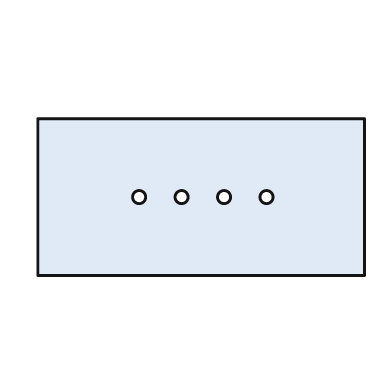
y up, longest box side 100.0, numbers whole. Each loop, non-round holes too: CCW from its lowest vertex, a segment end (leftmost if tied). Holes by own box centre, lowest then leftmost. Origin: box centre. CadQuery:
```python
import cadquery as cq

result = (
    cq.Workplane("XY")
    .moveTo(-50.0, -24.0)
    .lineTo(50.0, -24.0)
    .lineTo(50.0, 24.0)
    .lineTo(-50.0, 24.0)
    .close()
    .moveTo(-19.0, 0.0)
    .circle(2.0)
    .moveTo(-6.0, 0.0)
    .circle(2.0)
    .moveTo(7.0, 0.0)
    .circle(2.0)
    .moveTo(20.0, 0.0)
    .circle(2.0)
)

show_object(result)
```